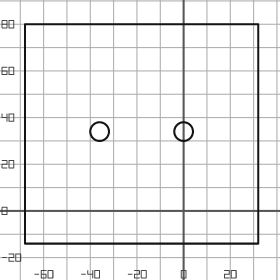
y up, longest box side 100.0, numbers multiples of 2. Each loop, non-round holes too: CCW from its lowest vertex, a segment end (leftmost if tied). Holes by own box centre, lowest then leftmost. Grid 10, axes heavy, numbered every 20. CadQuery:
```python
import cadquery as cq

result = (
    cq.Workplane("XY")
    .moveTo(-68.0, -14.0)
    .lineTo(32.0, -14.0)
    .lineTo(32.0, 80.0)
    .lineTo(-68.0, 80.0)
    .close()
    .moveTo(-36.0, 34.0)
    .circle(4.0)
    .moveTo(0.0, 34.0)
    .circle(4.0)
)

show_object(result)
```